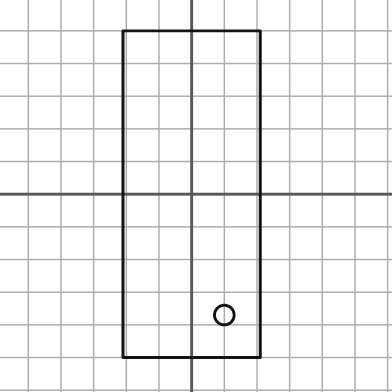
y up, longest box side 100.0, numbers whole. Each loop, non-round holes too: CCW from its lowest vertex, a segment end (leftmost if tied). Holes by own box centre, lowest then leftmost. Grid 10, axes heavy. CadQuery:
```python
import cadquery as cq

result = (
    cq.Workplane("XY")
    .moveTo(-21.0, -50.0)
    .lineTo(21.0, -50.0)
    .lineTo(21.0, 50.0)
    .lineTo(-21.0, 50.0)
    .close()
    .moveTo(10.0, -37.0)
    .circle(3.0)
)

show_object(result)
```